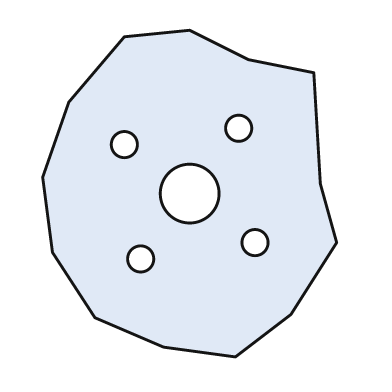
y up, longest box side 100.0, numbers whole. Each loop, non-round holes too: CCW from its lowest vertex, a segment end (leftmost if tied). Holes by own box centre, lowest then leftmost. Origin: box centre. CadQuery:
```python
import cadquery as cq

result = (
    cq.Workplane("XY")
    .moveTo(14.0, -50.0)
    .lineTo(31.0, -37.0)
    .lineTo(45.0, -15.0)
    .lineTo(40.0, 3.0)
    .lineTo(38.0, 37.0)
    .lineTo(18.0, 41.0)
    .lineTo(0.0, 50.0)
    .lineTo(-20.0, 48.0)
    .lineTo(-37.0, 28.0)
    .lineTo(-45.0, 5.0)
    .lineTo(-42.0, -18.0)
    .lineTo(-29.0, -38.0)
    .lineTo(-8.0, -47.0)
    .close()
    .moveTo(-15.0, -20.0)
    .circle(4.0)
    .moveTo(20.0, -15.0)
    .circle(4.0)
    .moveTo(0.0, 0.0)
    .circle(9.0)
    .moveTo(-20.0, 15.0)
    .circle(4.0)
    .moveTo(15.0, 20.0)
    .circle(4.0)
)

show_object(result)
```